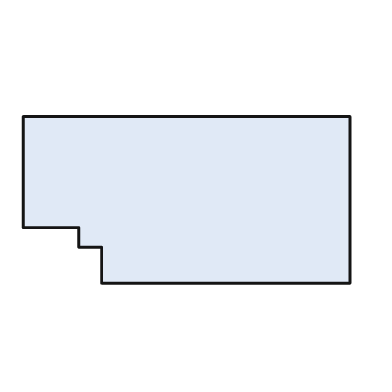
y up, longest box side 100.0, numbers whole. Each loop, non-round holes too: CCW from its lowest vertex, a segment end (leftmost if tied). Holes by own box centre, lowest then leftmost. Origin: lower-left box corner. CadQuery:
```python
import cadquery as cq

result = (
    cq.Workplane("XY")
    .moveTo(24.0, 0.0)
    .lineTo(100.0, 0.0)
    .lineTo(100.0, 51.0)
    .lineTo(0.0, 51.0)
    .lineTo(0.0, 17.0)
    .lineTo(17.0, 17.0)
    .lineTo(17.0, 11.0)
    .lineTo(24.0, 11.0)
    .close()
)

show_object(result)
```